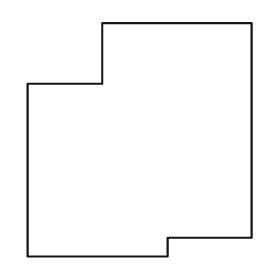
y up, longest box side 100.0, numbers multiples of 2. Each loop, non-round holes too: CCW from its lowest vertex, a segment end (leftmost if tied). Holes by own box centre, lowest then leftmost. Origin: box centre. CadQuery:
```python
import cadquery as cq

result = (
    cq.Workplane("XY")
    .moveTo(-48.0, -50.0)
    .lineTo(12.0, -50.0)
    .lineTo(12.0, -42.0)
    .lineTo(48.0, -42.0)
    .lineTo(48.0, 50.0)
    .lineTo(-16.0, 50.0)
    .lineTo(-16.0, 24.0)
    .lineTo(-48.0, 24.0)
    .close()
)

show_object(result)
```